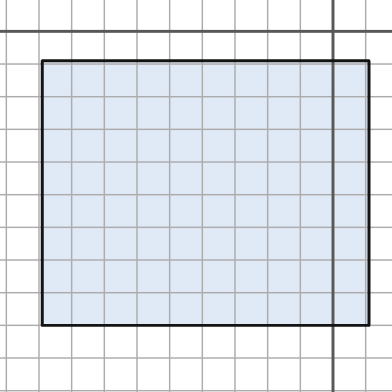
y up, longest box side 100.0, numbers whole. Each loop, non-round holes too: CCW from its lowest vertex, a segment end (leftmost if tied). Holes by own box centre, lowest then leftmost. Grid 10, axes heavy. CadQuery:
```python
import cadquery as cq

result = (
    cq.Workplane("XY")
    .moveTo(-89.0, -90.0)
    .lineTo(11.0, -90.0)
    .lineTo(11.0, -9.0)
    .lineTo(-89.0, -9.0)
    .close()
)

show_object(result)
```